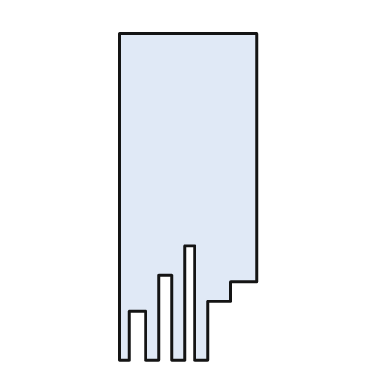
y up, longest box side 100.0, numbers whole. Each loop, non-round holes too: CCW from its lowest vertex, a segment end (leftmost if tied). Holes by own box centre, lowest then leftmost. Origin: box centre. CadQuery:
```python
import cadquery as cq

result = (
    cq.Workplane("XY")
    .moveTo(-21.0, -50.0)
    .lineTo(-18.0, -50.0)
    .lineTo(-18.0, -35.0)
    .lineTo(-13.0, -35.0)
    .lineTo(-13.0, -50.0)
    .lineTo(-9.0, -50.0)
    .lineTo(-9.0, -24.0)
    .lineTo(-5.0, -24.0)
    .lineTo(-5.0, -50.0)
    .lineTo(-1.0, -50.0)
    .lineTo(-1.0, -15.0)
    .lineTo(2.0, -15.0)
    .lineTo(2.0, -50.0)
    .lineTo(6.0, -50.0)
    .lineTo(6.0, -32.0)
    .lineTo(13.0, -32.0)
    .lineTo(13.0, -26.0)
    .lineTo(21.0, -26.0)
    .lineTo(21.0, 50.0)
    .lineTo(-21.0, 50.0)
    .close()
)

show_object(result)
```